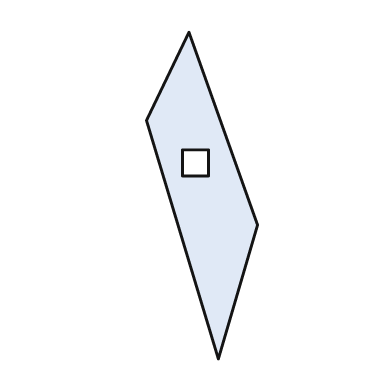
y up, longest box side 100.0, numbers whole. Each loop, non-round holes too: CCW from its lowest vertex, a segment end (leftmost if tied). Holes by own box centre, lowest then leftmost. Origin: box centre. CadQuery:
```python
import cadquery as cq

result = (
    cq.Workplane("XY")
    .moveTo(5.0, -50.0)
    .lineTo(17.0, -9.0)
    .lineTo(-4.0, 50.0)
    .lineTo(-17.0, 23.0)
    .close()
    .moveTo(-6.0, 6.0)
    .lineTo(2.0, 6.0)
    .lineTo(2.0, 14.0)
    .lineTo(-6.0, 14.0)
    .close()
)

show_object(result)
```